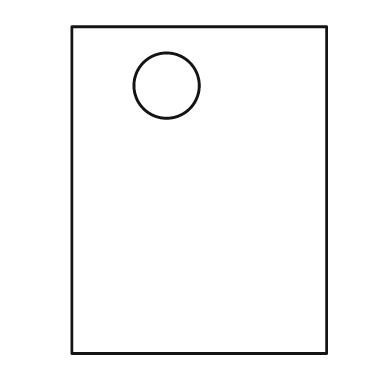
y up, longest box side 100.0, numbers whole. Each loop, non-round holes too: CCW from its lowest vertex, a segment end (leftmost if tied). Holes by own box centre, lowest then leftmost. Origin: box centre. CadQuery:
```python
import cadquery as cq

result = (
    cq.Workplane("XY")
    .moveTo(-39.0, -50.0)
    .lineTo(39.0, -50.0)
    .lineTo(39.0, 50.0)
    .lineTo(-39.0, 50.0)
    .close()
    .moveTo(-10.0, 32.0)
    .circle(10.0)
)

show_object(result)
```